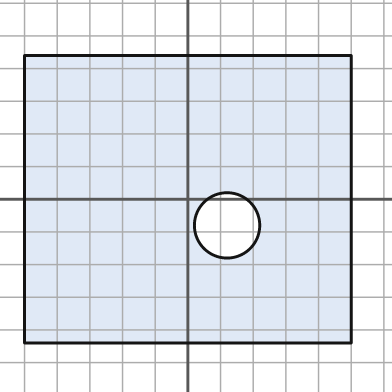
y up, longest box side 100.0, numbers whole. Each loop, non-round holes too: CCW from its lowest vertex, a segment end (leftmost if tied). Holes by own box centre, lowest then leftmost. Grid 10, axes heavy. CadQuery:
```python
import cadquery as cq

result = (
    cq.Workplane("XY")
    .moveTo(-50.0, -44.0)
    .lineTo(50.0, -44.0)
    .lineTo(50.0, 44.0)
    .lineTo(-50.0, 44.0)
    .close()
    .moveTo(12.0, -8.0)
    .circle(10.0)
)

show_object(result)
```